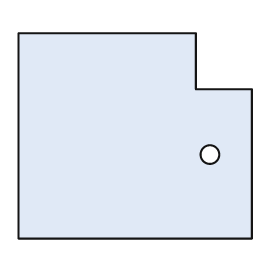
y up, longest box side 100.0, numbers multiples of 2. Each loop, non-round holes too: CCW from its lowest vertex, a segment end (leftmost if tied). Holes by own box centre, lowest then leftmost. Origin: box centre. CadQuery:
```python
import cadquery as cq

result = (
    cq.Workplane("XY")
    .moveTo(-50.0, -44.0)
    .lineTo(50.0, -44.0)
    .lineTo(50.0, 20.0)
    .lineTo(26.0, 20.0)
    .lineTo(26.0, 44.0)
    .lineTo(-50.0, 44.0)
    .close()
    .moveTo(32.0, -8.0)
    .circle(4.0)
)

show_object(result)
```